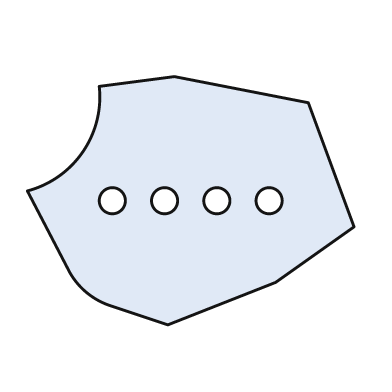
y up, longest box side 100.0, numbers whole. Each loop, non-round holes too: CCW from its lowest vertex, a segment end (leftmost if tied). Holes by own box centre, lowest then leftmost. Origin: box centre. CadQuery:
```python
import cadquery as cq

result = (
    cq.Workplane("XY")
    .moveTo(-7.0, -38.0)
    .lineTo(26.0, -25.0)
    .lineTo(50.0, -8.0)
    .lineTo(36.0, 30.0)
    .lineTo(-5.0, 38.0)
    .lineTo(-28.0, 35.0)
    .threePointArc((-33.0, 15.0), (-50.0, 3.0))
    .lineTo(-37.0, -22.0)
    .threePointArc((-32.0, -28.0), (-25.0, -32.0))
    .close()
    .moveTo(-24.0, 0.0)
    .circle(4.0)
    .moveTo(-8.0, 0.0)
    .circle(4.0)
    .moveTo(8.0, 0.0)
    .circle(4.0)
    .moveTo(24.0, 0.0)
    .circle(4.0)
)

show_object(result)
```